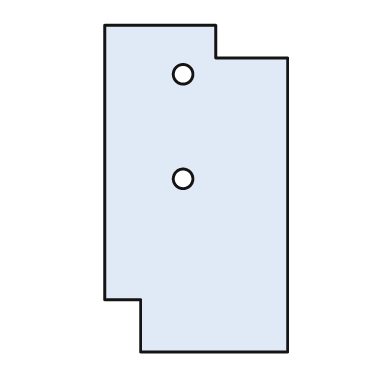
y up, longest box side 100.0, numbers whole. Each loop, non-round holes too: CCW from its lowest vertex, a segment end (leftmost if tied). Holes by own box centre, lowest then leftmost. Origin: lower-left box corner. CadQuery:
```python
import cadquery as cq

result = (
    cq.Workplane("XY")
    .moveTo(11.0, 0.0)
    .lineTo(56.0, 0.0)
    .lineTo(56.0, 90.0)
    .lineTo(34.0, 90.0)
    .lineTo(34.0, 100.0)
    .lineTo(0.0, 100.0)
    .lineTo(0.0, 16.0)
    .lineTo(11.0, 16.0)
    .close()
    .moveTo(24.0, 53.0)
    .circle(3.0)
    .moveTo(24.0, 85.0)
    .circle(3.0)
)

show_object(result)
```